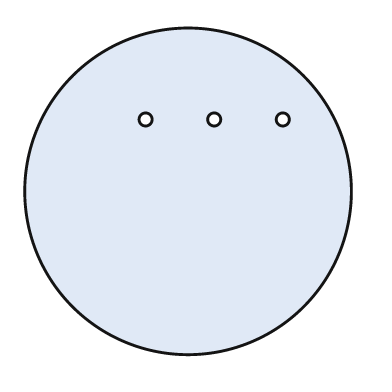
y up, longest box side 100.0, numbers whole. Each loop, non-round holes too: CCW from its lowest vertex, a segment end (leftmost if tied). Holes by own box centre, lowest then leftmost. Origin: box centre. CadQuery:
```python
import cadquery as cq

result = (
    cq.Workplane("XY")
    .moveTo(0.0, 0.0)
    .circle(50.0)
    .moveTo(-13.0, 22.0)
    .circle(2.0)
    .moveTo(8.0, 22.0)
    .circle(2.0)
    .moveTo(29.0, 22.0)
    .circle(2.0)
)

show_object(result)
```